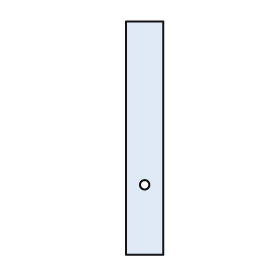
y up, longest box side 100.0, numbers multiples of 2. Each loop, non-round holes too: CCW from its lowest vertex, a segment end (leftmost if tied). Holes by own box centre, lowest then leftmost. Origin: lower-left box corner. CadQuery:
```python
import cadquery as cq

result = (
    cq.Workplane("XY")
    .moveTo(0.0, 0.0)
    .lineTo(16.0, 0.0)
    .lineTo(16.0, 100.0)
    .lineTo(0.0, 100.0)
    .close()
    .moveTo(8.0, 30.0)
    .circle(2.0)
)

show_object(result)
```